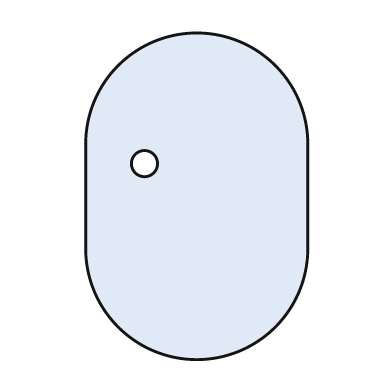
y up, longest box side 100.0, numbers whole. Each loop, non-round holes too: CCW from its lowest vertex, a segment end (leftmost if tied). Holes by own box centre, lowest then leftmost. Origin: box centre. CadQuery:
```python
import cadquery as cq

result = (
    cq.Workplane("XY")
    .moveTo(-34.0, -16.0)
    .threePointArc((0.0, -50.0), (34.0, -16.0))
    .lineTo(34.0, 16.0)
    .threePointArc((0.0, 50.0), (-34.0, 16.0))
    .close()
    .moveTo(-16.0, 10.0)
    .circle(4.0)
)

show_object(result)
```